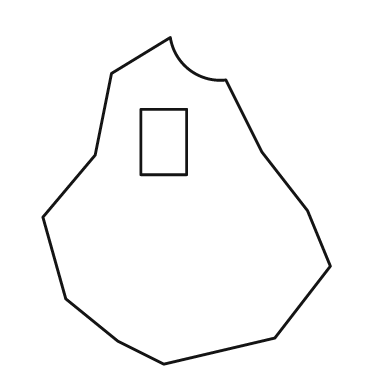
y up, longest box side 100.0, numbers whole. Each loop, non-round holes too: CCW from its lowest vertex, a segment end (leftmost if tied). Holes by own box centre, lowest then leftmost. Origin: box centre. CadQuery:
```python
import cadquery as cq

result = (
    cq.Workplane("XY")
    .moveTo(-7.0, -50.0)
    .lineTo(27.0, -42.0)
    .lineTo(44.0, -20.0)
    .lineTo(37.0, -3.0)
    .lineTo(23.0, 15.0)
    .lineTo(12.0, 37.0)
    .threePointArc((1.0, 40.0), (-5.0, 50.0))
    .lineTo(-23.0, 39.0)
    .lineTo(-28.0, 14.0)
    .lineTo(-44.0, -5.0)
    .lineTo(-37.0, -30.0)
    .lineTo(-21.0, -43.0)
    .close()
    .moveTo(-14.0, 8.0)
    .lineTo(0.0, 8.0)
    .lineTo(0.0, 28.0)
    .lineTo(-14.0, 28.0)
    .close()
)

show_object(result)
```